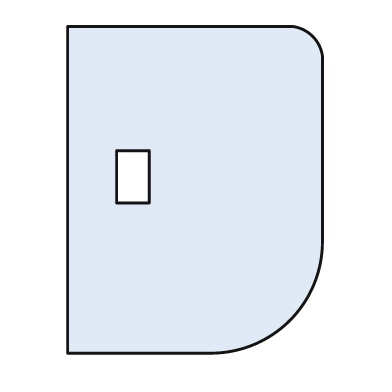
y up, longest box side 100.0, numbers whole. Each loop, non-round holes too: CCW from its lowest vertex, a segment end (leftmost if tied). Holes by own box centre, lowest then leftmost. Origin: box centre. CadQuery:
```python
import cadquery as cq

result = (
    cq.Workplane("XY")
    .moveTo(-39.0, -50.0)
    .lineTo(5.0, -50.0)
    .threePointArc((29.0, -40.0), (39.0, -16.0))
    .lineTo(39.0, 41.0)
    .threePointArc((36.0, 47.0), (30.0, 50.0))
    .lineTo(-39.0, 50.0)
    .close()
    .moveTo(-24.0, -4.0)
    .lineTo(-14.0, -4.0)
    .lineTo(-14.0, 12.0)
    .lineTo(-24.0, 12.0)
    .close()
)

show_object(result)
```